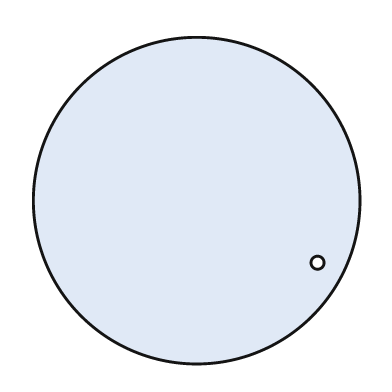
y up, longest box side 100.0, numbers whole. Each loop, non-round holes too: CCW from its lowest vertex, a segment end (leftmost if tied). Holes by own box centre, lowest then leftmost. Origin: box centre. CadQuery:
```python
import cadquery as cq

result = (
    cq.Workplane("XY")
    .moveTo(0.0, 0.0)
    .circle(50.0)
    .moveTo(37.0, -19.0)
    .circle(2.0)
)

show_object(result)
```